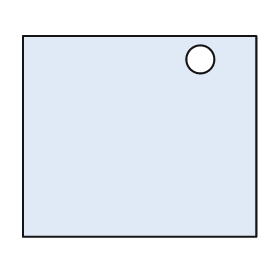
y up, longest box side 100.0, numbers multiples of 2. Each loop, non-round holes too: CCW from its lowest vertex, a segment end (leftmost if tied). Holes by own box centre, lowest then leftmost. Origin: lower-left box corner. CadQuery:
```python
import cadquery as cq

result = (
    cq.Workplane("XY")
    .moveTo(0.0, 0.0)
    .lineTo(100.0, 0.0)
    .lineTo(100.0, 86.0)
    .lineTo(0.0, 86.0)
    .close()
    .moveTo(76.0, 76.0)
    .circle(6.0)
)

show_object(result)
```